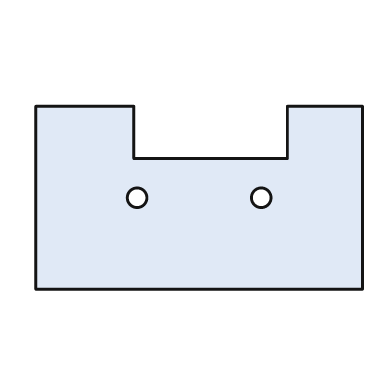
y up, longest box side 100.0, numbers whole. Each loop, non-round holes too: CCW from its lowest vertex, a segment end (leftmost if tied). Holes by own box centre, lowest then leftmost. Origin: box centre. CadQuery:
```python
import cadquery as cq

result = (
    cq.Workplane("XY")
    .moveTo(-50.0, -28.0)
    .lineTo(50.0, -28.0)
    .lineTo(50.0, 28.0)
    .lineTo(27.0, 28.0)
    .lineTo(27.0, 12.0)
    .lineTo(-20.0, 12.0)
    .lineTo(-20.0, 28.0)
    .lineTo(-50.0, 28.0)
    .close()
    .moveTo(-19.0, 0.0)
    .circle(3.0)
    .moveTo(19.0, 0.0)
    .circle(3.0)
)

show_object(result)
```